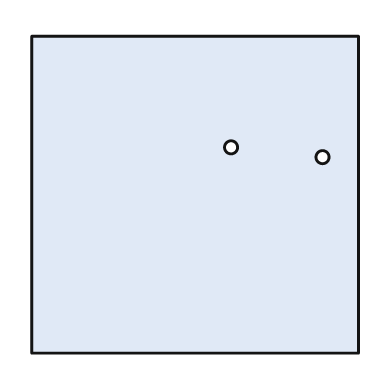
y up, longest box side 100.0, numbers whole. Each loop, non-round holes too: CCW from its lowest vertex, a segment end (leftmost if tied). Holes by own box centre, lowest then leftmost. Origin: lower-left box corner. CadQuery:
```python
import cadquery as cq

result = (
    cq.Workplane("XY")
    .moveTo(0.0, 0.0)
    .lineTo(100.0, 0.0)
    .lineTo(100.0, 97.0)
    .lineTo(0.0, 97.0)
    .close()
    .moveTo(89.0, 60.0)
    .circle(2.0)
    .moveTo(61.0, 63.0)
    .circle(2.0)
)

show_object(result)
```